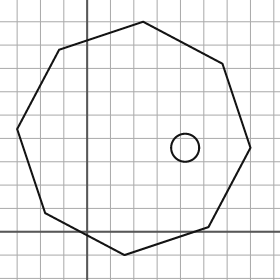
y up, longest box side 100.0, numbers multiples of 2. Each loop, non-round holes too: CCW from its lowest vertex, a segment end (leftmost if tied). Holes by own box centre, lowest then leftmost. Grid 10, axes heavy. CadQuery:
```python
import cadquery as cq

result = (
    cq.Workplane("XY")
    .moveTo(16.0, -10.0)
    .lineTo(52.0, 2.0)
    .lineTo(70.0, 36.0)
    .lineTo(58.0, 72.0)
    .lineTo(24.0, 90.0)
    .lineTo(-12.0, 78.0)
    .lineTo(-30.0, 44.0)
    .lineTo(-18.0, 8.0)
    .close()
    .moveTo(42.0, 36.0)
    .circle(6.0)
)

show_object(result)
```